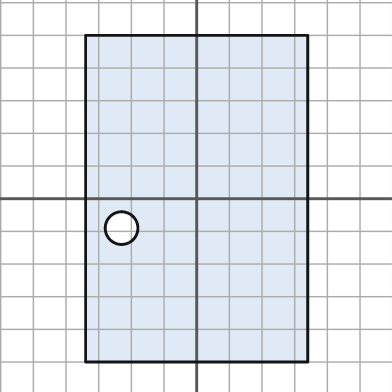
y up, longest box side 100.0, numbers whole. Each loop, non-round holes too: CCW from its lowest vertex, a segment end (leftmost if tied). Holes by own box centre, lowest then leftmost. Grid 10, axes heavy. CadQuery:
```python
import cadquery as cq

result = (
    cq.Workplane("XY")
    .moveTo(-34.0, -50.0)
    .lineTo(34.0, -50.0)
    .lineTo(34.0, 50.0)
    .lineTo(-34.0, 50.0)
    .close()
    .moveTo(-23.0, -9.0)
    .circle(5.0)
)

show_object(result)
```